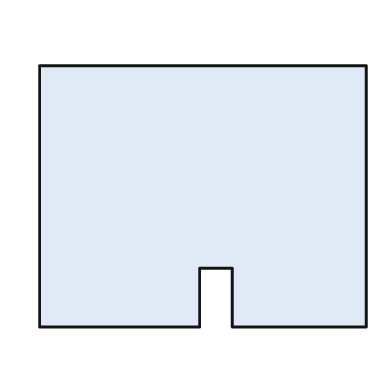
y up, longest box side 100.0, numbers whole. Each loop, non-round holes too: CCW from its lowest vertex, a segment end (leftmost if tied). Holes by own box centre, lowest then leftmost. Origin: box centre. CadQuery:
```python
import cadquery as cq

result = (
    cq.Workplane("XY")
    .moveTo(-50.0, -40.0)
    .lineTo(-1.0, -40.0)
    .lineTo(-1.0, -22.0)
    .lineTo(9.0, -22.0)
    .lineTo(9.0, -40.0)
    .lineTo(50.0, -40.0)
    .lineTo(50.0, 40.0)
    .lineTo(-50.0, 40.0)
    .close()
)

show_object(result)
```